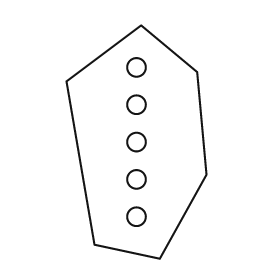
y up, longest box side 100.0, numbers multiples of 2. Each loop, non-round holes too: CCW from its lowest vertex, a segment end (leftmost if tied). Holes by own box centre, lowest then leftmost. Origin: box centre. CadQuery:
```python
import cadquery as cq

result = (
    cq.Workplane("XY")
    .moveTo(10.0, -50.0)
    .lineTo(30.0, -14.0)
    .lineTo(26.0, 30.0)
    .lineTo(2.0, 50.0)
    .lineTo(-30.0, 26.0)
    .lineTo(-18.0, -44.0)
    .close()
    .moveTo(0.0, -32.0)
    .circle(4.0)
    .moveTo(0.0, -16.0)
    .circle(4.0)
    .moveTo(0.0, 0.0)
    .circle(4.0)
    .moveTo(0.0, 16.0)
    .circle(4.0)
    .moveTo(0.0, 32.0)
    .circle(4.0)
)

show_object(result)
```